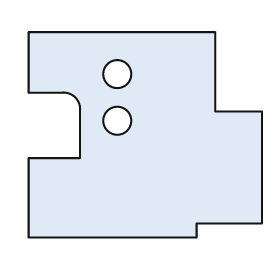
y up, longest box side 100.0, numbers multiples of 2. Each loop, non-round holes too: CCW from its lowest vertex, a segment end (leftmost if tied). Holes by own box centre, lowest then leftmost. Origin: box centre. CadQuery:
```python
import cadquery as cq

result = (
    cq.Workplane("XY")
    .moveTo(-50.0, -44.0)
    .lineTo(22.0, -44.0)
    .lineTo(22.0, -38.0)
    .lineTo(50.0, -38.0)
    .lineTo(50.0, 10.0)
    .lineTo(30.0, 10.0)
    .lineTo(30.0, 44.0)
    .lineTo(-50.0, 44.0)
    .lineTo(-50.0, 18.0)
    .lineTo(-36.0, 18.0)
    .threePointArc((-30.0, 16.0), (-28.0, 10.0))
    .lineTo(-28.0, -10.0)
    .lineTo(-50.0, -10.0)
    .close()
    .moveTo(-12.0, 6.0)
    .circle(6.0)
    .moveTo(-12.0, 26.0)
    .circle(6.0)
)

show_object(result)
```